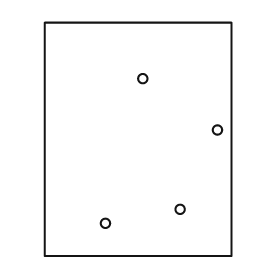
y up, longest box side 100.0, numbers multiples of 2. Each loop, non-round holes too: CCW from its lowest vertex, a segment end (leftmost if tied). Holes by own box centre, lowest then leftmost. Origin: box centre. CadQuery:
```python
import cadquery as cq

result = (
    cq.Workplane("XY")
    .moveTo(-40.0, -50.0)
    .lineTo(40.0, -50.0)
    .lineTo(40.0, 50.0)
    .lineTo(-40.0, 50.0)
    .close()
    .moveTo(-14.0, -36.0)
    .circle(2.0)
    .moveTo(18.0, -30.0)
    .circle(2.0)
    .moveTo(34.0, 4.0)
    .circle(2.0)
    .moveTo(2.0, 26.0)
    .circle(2.0)
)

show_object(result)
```